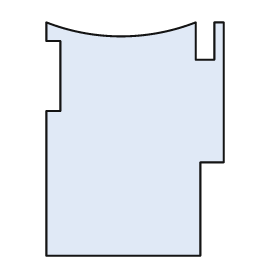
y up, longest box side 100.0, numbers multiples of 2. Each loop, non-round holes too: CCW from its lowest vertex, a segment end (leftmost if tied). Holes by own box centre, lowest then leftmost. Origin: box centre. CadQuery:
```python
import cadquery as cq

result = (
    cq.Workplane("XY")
    .moveTo(-38.0, -50.0)
    .lineTo(28.0, -50.0)
    .lineTo(28.0, -10.0)
    .lineTo(38.0, -10.0)
    .lineTo(38.0, 50.0)
    .lineTo(34.0, 50.0)
    .lineTo(34.0, 34.0)
    .lineTo(26.0, 34.0)
    .lineTo(26.0, 50.0)
    .threePointArc((-6.0, 44.0), (-38.0, 50.0))
    .lineTo(-38.0, 42.0)
    .lineTo(-32.0, 42.0)
    .lineTo(-32.0, 12.0)
    .lineTo(-38.0, 12.0)
    .close()
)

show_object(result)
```